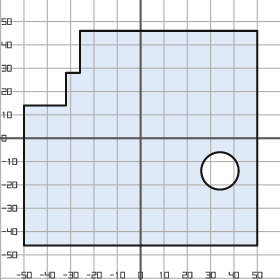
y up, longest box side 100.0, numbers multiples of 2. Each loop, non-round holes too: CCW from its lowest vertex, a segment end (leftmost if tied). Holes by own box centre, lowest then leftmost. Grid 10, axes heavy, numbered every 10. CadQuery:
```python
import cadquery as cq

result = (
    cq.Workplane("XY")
    .moveTo(-50.0, -46.0)
    .lineTo(50.0, -46.0)
    .lineTo(50.0, 46.0)
    .lineTo(-26.0, 46.0)
    .lineTo(-26.0, 28.0)
    .lineTo(-32.0, 28.0)
    .lineTo(-32.0, 14.0)
    .lineTo(-50.0, 14.0)
    .close()
    .moveTo(34.0, -14.0)
    .circle(8.0)
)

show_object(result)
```